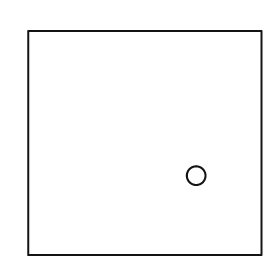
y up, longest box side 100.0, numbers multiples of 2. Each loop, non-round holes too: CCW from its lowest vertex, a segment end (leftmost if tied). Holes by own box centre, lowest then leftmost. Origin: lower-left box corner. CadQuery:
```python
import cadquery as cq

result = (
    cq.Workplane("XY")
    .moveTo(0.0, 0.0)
    .lineTo(100.0, 0.0)
    .lineTo(100.0, 96.0)
    .lineTo(0.0, 96.0)
    .close()
    .moveTo(72.0, 34.0)
    .circle(4.0)
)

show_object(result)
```